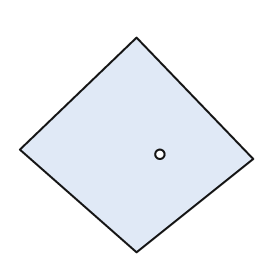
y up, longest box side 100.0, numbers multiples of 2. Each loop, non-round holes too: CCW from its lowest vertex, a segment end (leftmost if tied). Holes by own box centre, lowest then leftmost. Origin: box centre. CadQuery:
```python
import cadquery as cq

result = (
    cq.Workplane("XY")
    .moveTo(0.0, -46.0)
    .lineTo(50.0, -6.0)
    .lineTo(0.0, 46.0)
    .lineTo(-50.0, -2.0)
    .close()
    .moveTo(10.0, -4.0)
    .circle(2.0)
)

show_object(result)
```